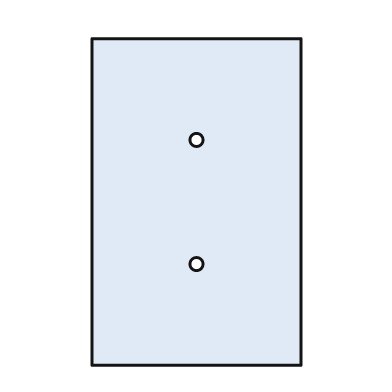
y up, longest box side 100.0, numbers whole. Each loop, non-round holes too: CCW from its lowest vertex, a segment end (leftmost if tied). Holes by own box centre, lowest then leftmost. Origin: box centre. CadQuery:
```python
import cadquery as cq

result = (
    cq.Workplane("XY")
    .moveTo(-32.0, -50.0)
    .lineTo(32.0, -50.0)
    .lineTo(32.0, 50.0)
    .lineTo(-32.0, 50.0)
    .close()
    .moveTo(0.0, -19.0)
    .circle(2.0)
    .moveTo(0.0, 19.0)
    .circle(2.0)
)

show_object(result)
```